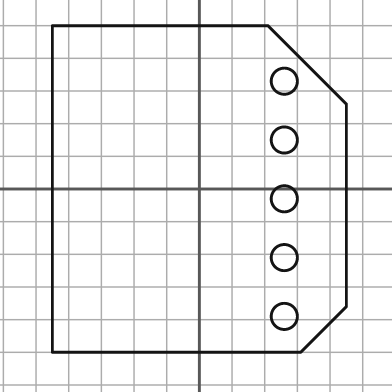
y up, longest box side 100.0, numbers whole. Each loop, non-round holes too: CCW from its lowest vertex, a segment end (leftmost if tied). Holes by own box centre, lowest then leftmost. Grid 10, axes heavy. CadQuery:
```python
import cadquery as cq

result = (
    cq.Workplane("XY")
    .moveTo(-45.0, -50.0)
    .lineTo(31.0, -50.0)
    .lineTo(45.0, -36.0)
    .lineTo(45.0, 26.0)
    .lineTo(21.0, 50.0)
    .lineTo(-45.0, 50.0)
    .close()
    .moveTo(26.0, -39.0)
    .circle(4.0)
    .moveTo(26.0, -21.0)
    .circle(4.0)
    .moveTo(26.0, -3.0)
    .circle(4.0)
    .moveTo(26.0, 15.0)
    .circle(4.0)
    .moveTo(26.0, 33.0)
    .circle(4.0)
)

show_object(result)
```